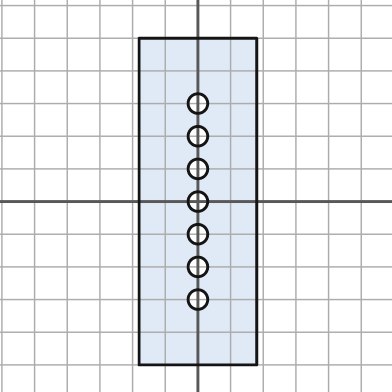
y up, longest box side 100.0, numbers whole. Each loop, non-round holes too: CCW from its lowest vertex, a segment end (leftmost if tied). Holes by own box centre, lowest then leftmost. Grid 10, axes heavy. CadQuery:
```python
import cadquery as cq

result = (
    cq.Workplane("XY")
    .moveTo(-18.0, -50.0)
    .lineTo(18.0, -50.0)
    .lineTo(18.0, 50.0)
    .lineTo(-18.0, 50.0)
    .close()
    .moveTo(0.0, -30.0)
    .circle(3.0)
    .moveTo(0.0, -20.0)
    .circle(3.0)
    .moveTo(0.0, -10.0)
    .circle(3.0)
    .moveTo(0.0, 0.0)
    .circle(3.0)
    .moveTo(0.0, 10.0)
    .circle(3.0)
    .moveTo(0.0, 20.0)
    .circle(3.0)
    .moveTo(0.0, 30.0)
    .circle(3.0)
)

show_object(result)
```